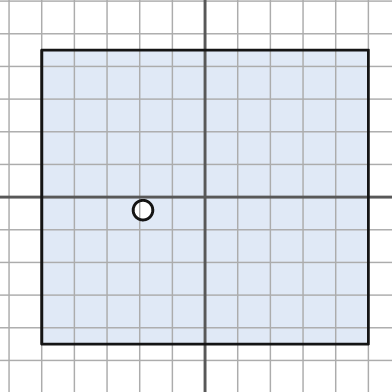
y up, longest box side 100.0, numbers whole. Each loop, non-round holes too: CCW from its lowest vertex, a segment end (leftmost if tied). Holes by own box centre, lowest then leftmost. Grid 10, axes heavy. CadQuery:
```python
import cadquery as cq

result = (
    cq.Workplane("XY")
    .moveTo(-50.0, -45.0)
    .lineTo(50.0, -45.0)
    .lineTo(50.0, 45.0)
    .lineTo(-50.0, 45.0)
    .close()
    .moveTo(-19.0, -4.0)
    .circle(3.0)
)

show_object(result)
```